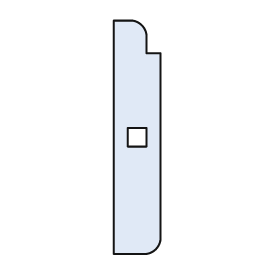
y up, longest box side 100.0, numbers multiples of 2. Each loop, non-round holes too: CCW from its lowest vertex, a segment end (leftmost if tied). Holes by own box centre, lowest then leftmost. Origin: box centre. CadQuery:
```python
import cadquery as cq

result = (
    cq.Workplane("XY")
    .moveTo(-10.0, -50.0)
    .lineTo(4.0, -50.0)
    .threePointArc((8.0, -48.0), (10.0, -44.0))
    .lineTo(10.0, 36.0)
    .lineTo(4.0, 36.0)
    .lineTo(4.0, 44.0)
    .threePointArc((2.0, 48.0), (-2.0, 50.0))
    .lineTo(-10.0, 50.0)
    .close()
    .moveTo(-4.0, -4.0)
    .lineTo(4.0, -4.0)
    .lineTo(4.0, 4.0)
    .lineTo(-4.0, 4.0)
    .close()
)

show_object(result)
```